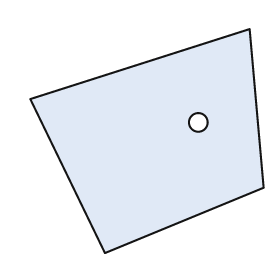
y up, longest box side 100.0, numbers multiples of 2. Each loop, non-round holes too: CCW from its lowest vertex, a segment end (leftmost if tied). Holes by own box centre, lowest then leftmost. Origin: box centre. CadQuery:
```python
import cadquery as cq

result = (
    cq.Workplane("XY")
    .moveTo(-18.0, -48.0)
    .lineTo(50.0, -20.0)
    .lineTo(44.0, 48.0)
    .lineTo(-50.0, 18.0)
    .close()
    .moveTo(22.0, 8.0)
    .circle(4.0)
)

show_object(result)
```